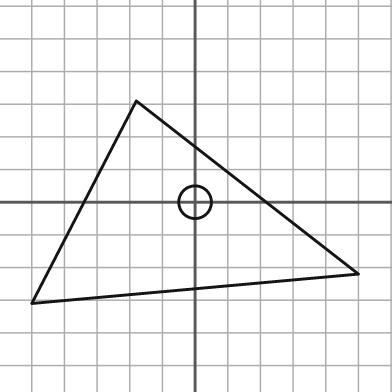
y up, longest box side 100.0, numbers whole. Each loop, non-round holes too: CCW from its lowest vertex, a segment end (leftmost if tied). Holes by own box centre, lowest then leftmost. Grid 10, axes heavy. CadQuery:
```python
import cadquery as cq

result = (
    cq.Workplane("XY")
    .moveTo(-50.0, -31.0)
    .lineTo(50.0, -22.0)
    .lineTo(-18.0, 31.0)
    .close()
    .moveTo(0.0, 0.0)
    .circle(5.0)
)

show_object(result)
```